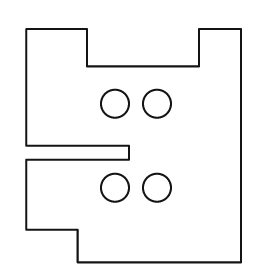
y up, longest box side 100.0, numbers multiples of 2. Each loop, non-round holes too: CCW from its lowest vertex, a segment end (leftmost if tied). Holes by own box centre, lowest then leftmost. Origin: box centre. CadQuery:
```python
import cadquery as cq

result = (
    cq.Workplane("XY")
    .moveTo(-24.0, -50.0)
    .lineTo(46.0, -50.0)
    .lineTo(46.0, 50.0)
    .lineTo(28.0, 50.0)
    .lineTo(28.0, 34.0)
    .lineTo(-20.0, 34.0)
    .lineTo(-20.0, 50.0)
    .lineTo(-46.0, 50.0)
    .lineTo(-46.0, 0.0)
    .lineTo(-2.0, 0.0)
    .lineTo(-2.0, -6.0)
    .lineTo(-46.0, -6.0)
    .lineTo(-46.0, -36.0)
    .lineTo(-24.0, -36.0)
    .close()
    .moveTo(-8.0, -18.0)
    .circle(6.0)
    .moveTo(10.0, -18.0)
    .circle(6.0)
    .moveTo(-8.0, 18.0)
    .circle(6.0)
    .moveTo(10.0, 18.0)
    .circle(6.0)
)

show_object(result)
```